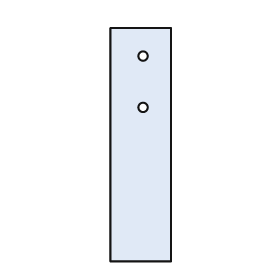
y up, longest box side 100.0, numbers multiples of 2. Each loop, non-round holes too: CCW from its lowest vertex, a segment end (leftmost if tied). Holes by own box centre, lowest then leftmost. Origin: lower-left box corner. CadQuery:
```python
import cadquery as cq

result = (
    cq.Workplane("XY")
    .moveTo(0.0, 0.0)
    .lineTo(26.0, 0.0)
    .lineTo(26.0, 100.0)
    .lineTo(0.0, 100.0)
    .close()
    .moveTo(14.0, 66.0)
    .circle(2.0)
    .moveTo(14.0, 88.0)
    .circle(2.0)
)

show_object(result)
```